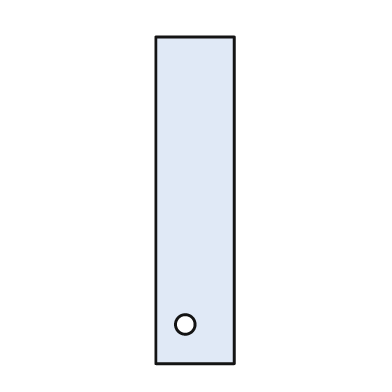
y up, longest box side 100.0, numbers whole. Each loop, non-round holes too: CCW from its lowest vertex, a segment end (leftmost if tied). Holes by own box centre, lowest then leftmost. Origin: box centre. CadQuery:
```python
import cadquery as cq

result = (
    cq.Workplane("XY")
    .moveTo(-12.0, -50.0)
    .lineTo(12.0, -50.0)
    .lineTo(12.0, 50.0)
    .lineTo(-12.0, 50.0)
    .close()
    .moveTo(-3.0, -38.0)
    .circle(3.0)
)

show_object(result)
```